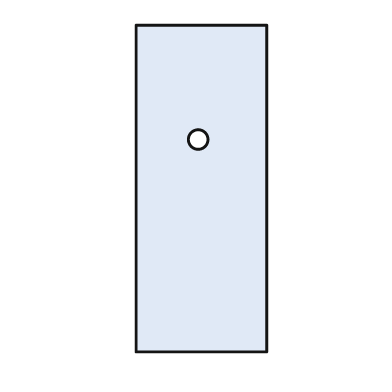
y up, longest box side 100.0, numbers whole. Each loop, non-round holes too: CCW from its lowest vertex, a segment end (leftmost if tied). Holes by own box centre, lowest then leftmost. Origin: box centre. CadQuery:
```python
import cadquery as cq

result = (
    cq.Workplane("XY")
    .moveTo(-20.0, -50.0)
    .lineTo(20.0, -50.0)
    .lineTo(20.0, 50.0)
    .lineTo(-20.0, 50.0)
    .close()
    .moveTo(-1.0, 15.0)
    .circle(3.0)
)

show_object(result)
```